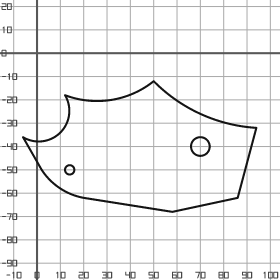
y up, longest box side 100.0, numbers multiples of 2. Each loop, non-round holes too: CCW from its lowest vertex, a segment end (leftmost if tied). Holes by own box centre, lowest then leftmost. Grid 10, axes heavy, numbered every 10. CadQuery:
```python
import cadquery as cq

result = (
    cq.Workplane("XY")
    .moveTo(58.0, -68.0)
    .lineTo(86.0, -62.0)
    .lineTo(94.0, -32.0)
    .threePointArc((70.0, -26.0), (50.0, -12.0))
    .threePointArc((32.0, -20.0), (12.0, -18.0))
    .threePointArc((10.0, -34.0), (-6.0, -36.0))
    .lineTo(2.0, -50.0)
    .threePointArc((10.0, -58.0), (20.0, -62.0))
    .close()
    .moveTo(14.0, -50.0)
    .circle(2.0)
    .moveTo(70.0, -40.0)
    .circle(4.0)
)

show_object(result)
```